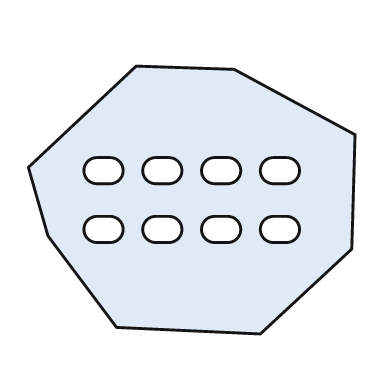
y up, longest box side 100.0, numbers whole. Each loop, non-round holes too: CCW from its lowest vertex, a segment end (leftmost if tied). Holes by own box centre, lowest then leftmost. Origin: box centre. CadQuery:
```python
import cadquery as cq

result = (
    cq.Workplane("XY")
    .moveTo(21.0, -41.0)
    .lineTo(49.0, -15.0)
    .lineTo(50.0, 20.0)
    .lineTo(13.0, 40.0)
    .lineTo(-17.0, 41.0)
    .lineTo(-50.0, 10.0)
    .lineTo(-44.0, -11.0)
    .lineTo(-23.0, -39.0)
    .close()
    .moveTo(-29.0, -13.0)
    .lineTo(-25.0, -13.0)
    .threePointArc((-21.0, -9.0), (-25.0, -5.0))
    .lineTo(-29.0, -5.0)
    .threePointArc((-33.0, -9.0), (-29.0, -13.0))
    .close()
    .moveTo(-11.0, -13.0)
    .lineTo(-7.0, -13.0)
    .threePointArc((-3.0, -9.0), (-7.0, -5.0))
    .lineTo(-11.0, -5.0)
    .threePointArc((-15.0, -9.0), (-11.0, -13.0))
    .close()
    .moveTo(7.0, -13.0)
    .lineTo(11.0, -13.0)
    .threePointArc((15.0, -9.0), (11.0, -5.0))
    .lineTo(7.0, -5.0)
    .threePointArc((3.0, -9.0), (7.0, -13.0))
    .close()
    .moveTo(25.0, -13.0)
    .lineTo(29.0, -13.0)
    .threePointArc((33.0, -9.0), (29.0, -5.0))
    .lineTo(25.0, -5.0)
    .threePointArc((21.0, -9.0), (25.0, -13.0))
    .close()
    .moveTo(-29.0, 5.0)
    .lineTo(-25.0, 5.0)
    .threePointArc((-21.0, 9.0), (-25.0, 13.0))
    .lineTo(-29.0, 13.0)
    .threePointArc((-33.0, 9.0), (-29.0, 5.0))
    .close()
    .moveTo(-11.0, 5.0)
    .lineTo(-7.0, 5.0)
    .threePointArc((-3.0, 9.0), (-7.0, 13.0))
    .lineTo(-11.0, 13.0)
    .threePointArc((-15.0, 9.0), (-11.0, 5.0))
    .close()
    .moveTo(7.0, 5.0)
    .lineTo(11.0, 5.0)
    .threePointArc((15.0, 9.0), (11.0, 13.0))
    .lineTo(7.0, 13.0)
    .threePointArc((3.0, 9.0), (7.0, 5.0))
    .close()
    .moveTo(25.0, 5.0)
    .lineTo(29.0, 5.0)
    .threePointArc((33.0, 9.0), (29.0, 13.0))
    .lineTo(25.0, 13.0)
    .threePointArc((21.0, 9.0), (25.0, 5.0))
    .close()
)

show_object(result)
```